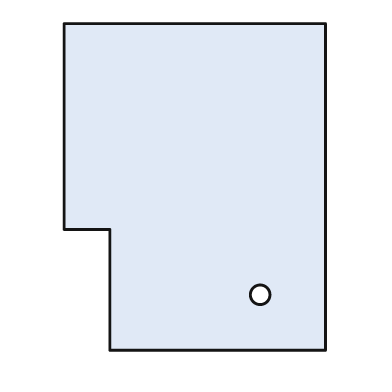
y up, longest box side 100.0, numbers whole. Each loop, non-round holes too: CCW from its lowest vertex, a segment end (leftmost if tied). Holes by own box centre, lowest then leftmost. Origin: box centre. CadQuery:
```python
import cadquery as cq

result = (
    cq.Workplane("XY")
    .moveTo(-26.0, -50.0)
    .lineTo(40.0, -50.0)
    .lineTo(40.0, 50.0)
    .lineTo(-40.0, 50.0)
    .lineTo(-40.0, -13.0)
    .lineTo(-26.0, -13.0)
    .close()
    .moveTo(20.0, -33.0)
    .circle(3.0)
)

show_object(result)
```